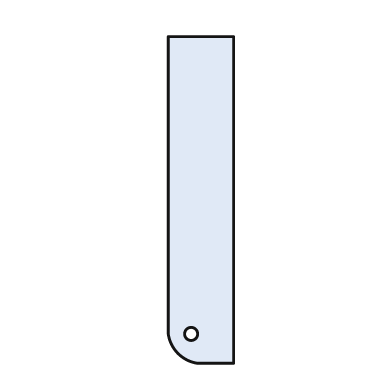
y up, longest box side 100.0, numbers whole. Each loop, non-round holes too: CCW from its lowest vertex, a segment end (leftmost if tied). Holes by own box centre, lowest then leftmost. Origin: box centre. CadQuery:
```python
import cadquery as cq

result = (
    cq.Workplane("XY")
    .moveTo(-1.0, -50.0)
    .lineTo(10.0, -50.0)
    .lineTo(10.0, 50.0)
    .lineTo(-10.0, 50.0)
    .lineTo(-10.0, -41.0)
    .threePointArc((-7.0, -47.0), (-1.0, -50.0))
    .close()
    .moveTo(-3.0, -41.0)
    .circle(2.0)
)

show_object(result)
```